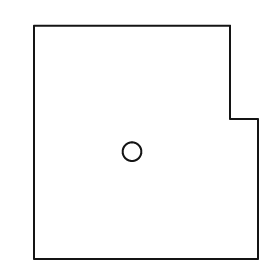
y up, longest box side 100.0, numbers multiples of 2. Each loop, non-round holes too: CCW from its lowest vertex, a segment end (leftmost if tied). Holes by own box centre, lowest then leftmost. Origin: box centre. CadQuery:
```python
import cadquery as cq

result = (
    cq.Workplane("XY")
    .moveTo(-48.0, -50.0)
    .lineTo(48.0, -50.0)
    .lineTo(48.0, 10.0)
    .lineTo(36.0, 10.0)
    .lineTo(36.0, 50.0)
    .lineTo(-48.0, 50.0)
    .close()
    .moveTo(-6.0, -4.0)
    .circle(4.0)
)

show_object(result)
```